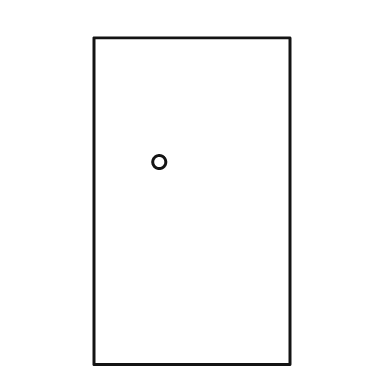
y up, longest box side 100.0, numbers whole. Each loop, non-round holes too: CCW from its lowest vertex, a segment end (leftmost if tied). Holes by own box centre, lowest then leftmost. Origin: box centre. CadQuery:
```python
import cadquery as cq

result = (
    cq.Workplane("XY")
    .moveTo(-30.0, -50.0)
    .lineTo(30.0, -50.0)
    .lineTo(30.0, 50.0)
    .lineTo(-30.0, 50.0)
    .close()
    .moveTo(-10.0, 12.0)
    .circle(2.0)
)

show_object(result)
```